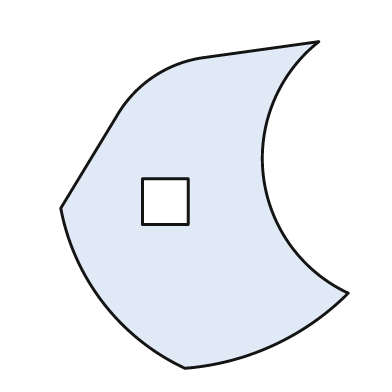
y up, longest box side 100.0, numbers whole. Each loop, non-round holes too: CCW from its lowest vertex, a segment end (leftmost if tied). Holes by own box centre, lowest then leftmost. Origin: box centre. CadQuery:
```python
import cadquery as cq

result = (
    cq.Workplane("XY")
    .moveTo(-6.0, -50.0)
    .threePointArc((21.0, -43.0), (44.0, -27.0))
    .threePointArc((18.0, 9.0), (35.0, 50.0))
    .lineTo(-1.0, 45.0)
    .threePointArc((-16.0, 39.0), (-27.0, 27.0))
    .lineTo(-44.0, -1.0)
    .threePointArc((-31.0, -30.0), (-6.0, -50.0))
    .close()
    .moveTo(-19.0, -6.0)
    .lineTo(-5.0, -6.0)
    .lineTo(-5.0, 8.0)
    .lineTo(-19.0, 8.0)
    .close()
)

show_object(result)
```